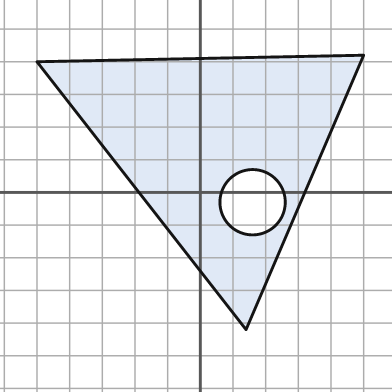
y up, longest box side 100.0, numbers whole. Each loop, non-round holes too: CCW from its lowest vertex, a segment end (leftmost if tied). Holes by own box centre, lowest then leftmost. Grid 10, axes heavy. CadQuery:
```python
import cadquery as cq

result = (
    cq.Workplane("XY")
    .moveTo(14.0, -42.0)
    .lineTo(50.0, 42.0)
    .lineTo(-50.0, 40.0)
    .close()
    .moveTo(16.0, -3.0)
    .circle(10.0)
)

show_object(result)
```